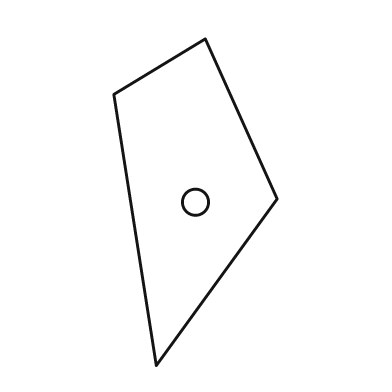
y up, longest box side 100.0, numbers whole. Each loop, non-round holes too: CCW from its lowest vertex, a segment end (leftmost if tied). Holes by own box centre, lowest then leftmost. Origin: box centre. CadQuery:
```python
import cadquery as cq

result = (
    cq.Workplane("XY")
    .moveTo(-12.0, -50.0)
    .lineTo(25.0, 1.0)
    .lineTo(3.0, 50.0)
    .lineTo(-25.0, 33.0)
    .close()
    .moveTo(0.0, 0.0)
    .circle(4.0)
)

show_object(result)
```